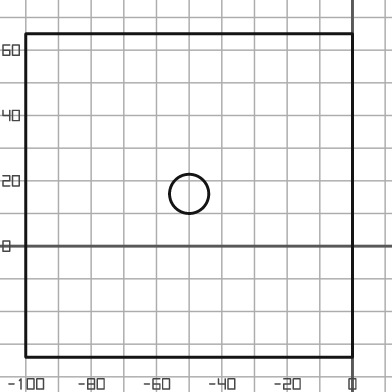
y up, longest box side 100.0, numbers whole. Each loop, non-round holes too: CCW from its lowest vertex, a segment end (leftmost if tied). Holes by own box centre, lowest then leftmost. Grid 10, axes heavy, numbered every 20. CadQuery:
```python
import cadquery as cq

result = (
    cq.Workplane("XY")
    .moveTo(-100.0, -34.0)
    .lineTo(0.0, -34.0)
    .lineTo(0.0, 65.0)
    .lineTo(-100.0, 65.0)
    .close()
    .moveTo(-50.0, 16.0)
    .circle(6.0)
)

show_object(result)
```